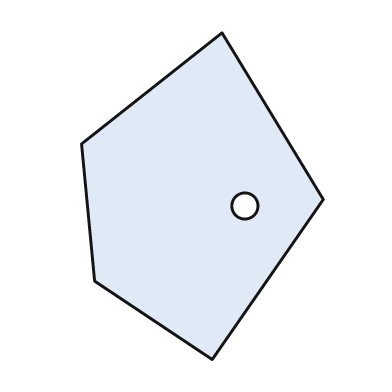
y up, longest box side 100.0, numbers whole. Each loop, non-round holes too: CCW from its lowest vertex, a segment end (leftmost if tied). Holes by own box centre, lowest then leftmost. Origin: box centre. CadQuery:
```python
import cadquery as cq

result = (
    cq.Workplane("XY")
    .moveTo(3.0, -50.0)
    .lineTo(37.0, -1.0)
    .lineTo(6.0, 50.0)
    .lineTo(-37.0, 16.0)
    .lineTo(-33.0, -26.0)
    .close()
    .moveTo(13.0, -3.0)
    .circle(4.0)
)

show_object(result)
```